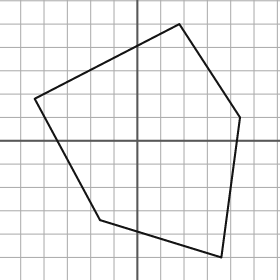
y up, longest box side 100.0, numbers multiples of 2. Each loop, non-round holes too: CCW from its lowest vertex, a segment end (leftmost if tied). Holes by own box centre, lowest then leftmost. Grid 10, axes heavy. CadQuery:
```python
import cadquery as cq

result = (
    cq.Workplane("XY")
    .moveTo(36.0, -50.0)
    .lineTo(44.0, 10.0)
    .lineTo(18.0, 50.0)
    .lineTo(-44.0, 18.0)
    .lineTo(-16.0, -34.0)
    .close()
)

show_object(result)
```